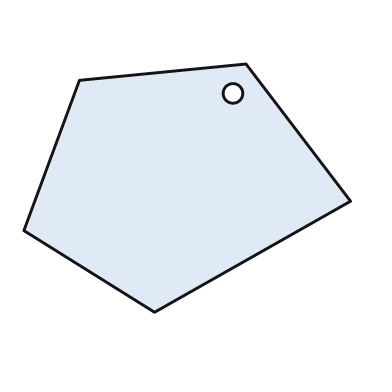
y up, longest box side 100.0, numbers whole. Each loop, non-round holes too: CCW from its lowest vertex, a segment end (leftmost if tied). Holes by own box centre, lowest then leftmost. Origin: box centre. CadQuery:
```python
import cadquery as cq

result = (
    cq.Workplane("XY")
    .moveTo(-10.0, -38.0)
    .lineTo(50.0, -4.0)
    .lineTo(18.0, 38.0)
    .lineTo(-33.0, 33.0)
    .lineTo(-50.0, -13.0)
    .close()
    .moveTo(14.0, 29.0)
    .circle(3.0)
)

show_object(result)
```